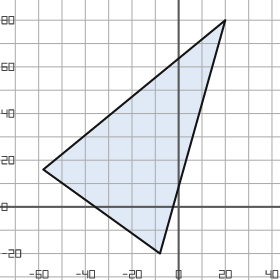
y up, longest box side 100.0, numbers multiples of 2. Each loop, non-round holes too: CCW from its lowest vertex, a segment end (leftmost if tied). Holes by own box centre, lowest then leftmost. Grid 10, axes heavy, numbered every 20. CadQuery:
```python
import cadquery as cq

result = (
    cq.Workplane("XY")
    .moveTo(-8.0, -20.0)
    .lineTo(20.0, 80.0)
    .lineTo(-58.0, 16.0)
    .close()
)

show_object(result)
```